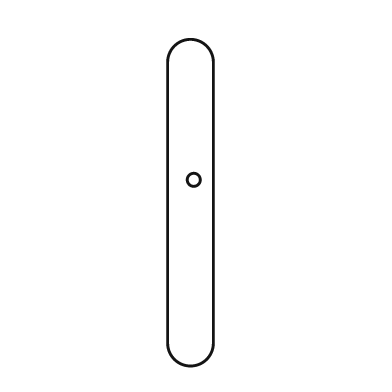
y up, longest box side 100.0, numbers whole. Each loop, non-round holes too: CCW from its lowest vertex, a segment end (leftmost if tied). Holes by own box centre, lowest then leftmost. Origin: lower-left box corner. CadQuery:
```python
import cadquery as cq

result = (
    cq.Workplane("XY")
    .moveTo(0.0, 7.0)
    .threePointArc((7.0, 0.0), (14.0, 7.0))
    .lineTo(14.0, 93.0)
    .threePointArc((7.0, 100.0), (0.0, 93.0))
    .close()
    .moveTo(8.0, 57.0)
    .circle(2.0)
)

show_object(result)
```